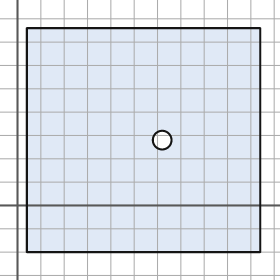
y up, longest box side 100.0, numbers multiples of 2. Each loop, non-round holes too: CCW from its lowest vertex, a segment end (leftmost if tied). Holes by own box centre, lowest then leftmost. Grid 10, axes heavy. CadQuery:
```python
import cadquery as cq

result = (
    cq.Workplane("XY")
    .moveTo(4.0, -20.0)
    .lineTo(104.0, -20.0)
    .lineTo(104.0, 76.0)
    .lineTo(4.0, 76.0)
    .close()
    .moveTo(62.0, 28.0)
    .circle(4.0)
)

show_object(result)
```